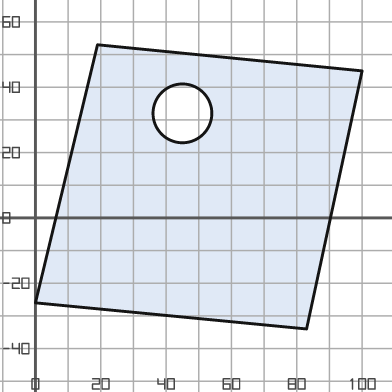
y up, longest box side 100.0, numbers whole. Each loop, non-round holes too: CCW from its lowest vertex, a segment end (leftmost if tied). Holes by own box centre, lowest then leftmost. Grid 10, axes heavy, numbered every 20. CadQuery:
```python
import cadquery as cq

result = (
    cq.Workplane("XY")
    .moveTo(83.0, -34.0)
    .lineTo(100.0, 45.0)
    .lineTo(19.0, 53.0)
    .lineTo(0.0, -26.0)
    .close()
    .moveTo(45.0, 32.0)
    .circle(9.0)
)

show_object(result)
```